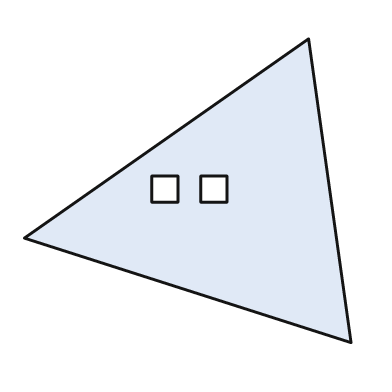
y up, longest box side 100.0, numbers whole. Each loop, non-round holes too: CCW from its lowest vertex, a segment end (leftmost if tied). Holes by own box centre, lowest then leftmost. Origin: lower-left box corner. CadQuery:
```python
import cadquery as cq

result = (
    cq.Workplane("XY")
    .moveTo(100.0, 0.0)
    .lineTo(87.0, 93.0)
    .lineTo(0.0, 32.0)
    .close()
    .moveTo(39.0, 43.0)
    .lineTo(47.0, 43.0)
    .lineTo(47.0, 51.0)
    .lineTo(39.0, 51.0)
    .close()
    .moveTo(54.0, 43.0)
    .lineTo(62.0, 43.0)
    .lineTo(62.0, 51.0)
    .lineTo(54.0, 51.0)
    .close()
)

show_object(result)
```